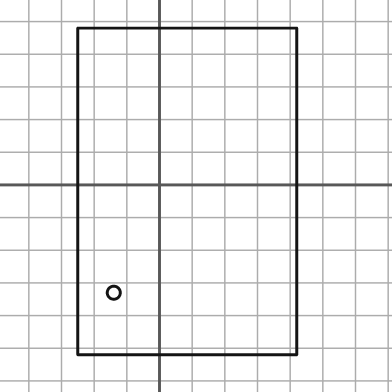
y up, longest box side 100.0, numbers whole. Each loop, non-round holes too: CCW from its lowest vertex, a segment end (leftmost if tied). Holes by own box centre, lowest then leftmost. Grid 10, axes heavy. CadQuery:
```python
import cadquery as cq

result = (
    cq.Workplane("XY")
    .moveTo(-25.0, -52.0)
    .lineTo(42.0, -52.0)
    .lineTo(42.0, 48.0)
    .lineTo(-25.0, 48.0)
    .close()
    .moveTo(-14.0, -33.0)
    .circle(2.0)
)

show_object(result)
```